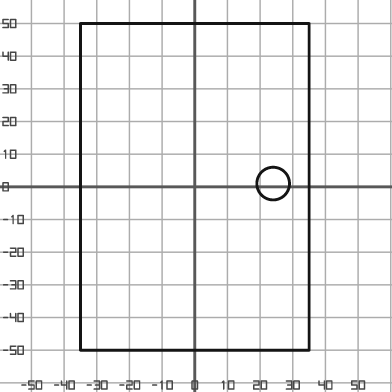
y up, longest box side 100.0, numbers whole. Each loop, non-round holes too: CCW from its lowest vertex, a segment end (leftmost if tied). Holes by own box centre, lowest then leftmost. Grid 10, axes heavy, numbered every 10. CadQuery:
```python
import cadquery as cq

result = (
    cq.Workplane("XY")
    .moveTo(-35.0, -50.0)
    .lineTo(35.0, -50.0)
    .lineTo(35.0, 50.0)
    .lineTo(-35.0, 50.0)
    .close()
    .moveTo(24.0, 1.0)
    .circle(5.0)
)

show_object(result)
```